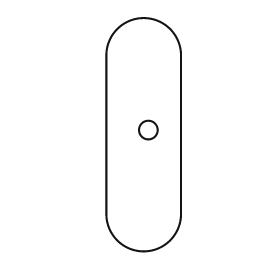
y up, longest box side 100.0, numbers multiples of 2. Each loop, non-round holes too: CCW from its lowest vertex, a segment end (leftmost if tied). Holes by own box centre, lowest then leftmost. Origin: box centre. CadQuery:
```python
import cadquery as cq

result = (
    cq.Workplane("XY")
    .moveTo(-16.0, -34.0)
    .threePointArc((0.0, -50.0), (16.0, -34.0))
    .lineTo(16.0, 34.0)
    .threePointArc((0.0, 50.0), (-16.0, 34.0))
    .close()
    .moveTo(2.0, 2.0)
    .circle(4.0)
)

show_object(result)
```